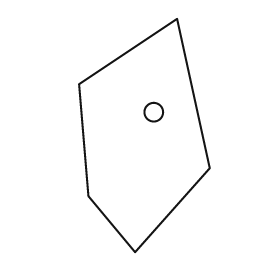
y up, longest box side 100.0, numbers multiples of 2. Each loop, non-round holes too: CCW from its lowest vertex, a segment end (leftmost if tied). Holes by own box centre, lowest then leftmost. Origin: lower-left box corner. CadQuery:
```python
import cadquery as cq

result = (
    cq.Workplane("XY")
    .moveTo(24.0, 0.0)
    .lineTo(56.0, 36.0)
    .lineTo(42.0, 100.0)
    .lineTo(0.0, 72.0)
    .lineTo(4.0, 24.0)
    .close()
    .moveTo(32.0, 60.0)
    .circle(4.0)
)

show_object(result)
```